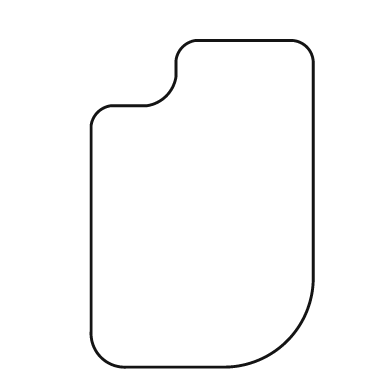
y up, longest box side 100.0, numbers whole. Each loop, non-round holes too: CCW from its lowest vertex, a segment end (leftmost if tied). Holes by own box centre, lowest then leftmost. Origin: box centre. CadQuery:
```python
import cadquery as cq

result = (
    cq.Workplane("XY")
    .moveTo(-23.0, -50.0)
    .lineTo(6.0, -50.0)
    .threePointArc((26.0, -42.0), (34.0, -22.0))
    .lineTo(34.0, 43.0)
    .threePointArc((32.0, 48.0), (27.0, 50.0))
    .lineTo(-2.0, 50.0)
    .threePointArc((-6.0, 48.0), (-8.0, 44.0))
    .lineTo(-8.0, 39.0)
    .threePointArc((-11.0, 33.0), (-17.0, 30.0))
    .lineTo(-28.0, 30.0)
    .threePointArc((-32.0, 28.0), (-34.0, 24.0))
    .lineTo(-34.0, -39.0)
    .threePointArc((-31.0, -47.0), (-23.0, -50.0))
    .close()
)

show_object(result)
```